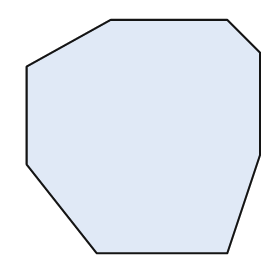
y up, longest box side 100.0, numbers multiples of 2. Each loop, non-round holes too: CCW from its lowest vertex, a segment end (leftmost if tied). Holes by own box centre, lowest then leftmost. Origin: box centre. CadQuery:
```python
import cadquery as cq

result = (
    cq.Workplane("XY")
    .moveTo(-20.0, -50.0)
    .lineTo(36.0, -50.0)
    .lineTo(50.0, -8.0)
    .lineTo(50.0, 36.0)
    .lineTo(36.0, 50.0)
    .lineTo(-14.0, 50.0)
    .lineTo(-50.0, 30.0)
    .lineTo(-50.0, -12.0)
    .close()
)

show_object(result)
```